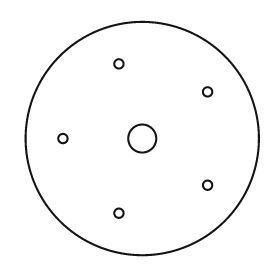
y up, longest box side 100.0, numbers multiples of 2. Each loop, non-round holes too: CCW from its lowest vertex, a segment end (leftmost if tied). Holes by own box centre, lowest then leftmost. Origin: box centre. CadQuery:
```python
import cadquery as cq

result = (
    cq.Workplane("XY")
    .moveTo(0.0, 0.0)
    .circle(50.0)
    .moveTo(-10.0, -32.0)
    .circle(2.0)
    .moveTo(28.0, -20.0)
    .circle(2.0)
    .moveTo(-34.0, 0.0)
    .circle(2.0)
    .moveTo(0.0, 0.0)
    .circle(6.0)
    .moveTo(28.0, 20.0)
    .circle(2.0)
    .moveTo(-10.0, 32.0)
    .circle(2.0)
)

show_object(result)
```